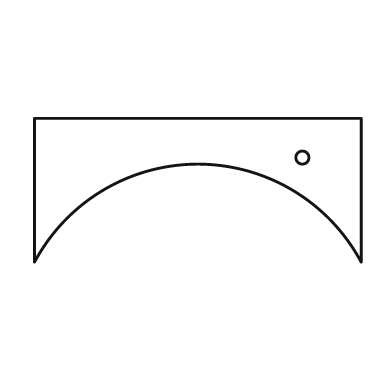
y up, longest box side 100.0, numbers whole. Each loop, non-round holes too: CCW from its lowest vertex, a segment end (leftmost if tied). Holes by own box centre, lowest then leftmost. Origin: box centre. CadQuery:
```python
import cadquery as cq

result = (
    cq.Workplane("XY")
    .moveTo(-50.0, -22.0)
    .threePointArc((0.0, 8.0), (50.0, -22.0))
    .lineTo(50.0, 22.0)
    .lineTo(-50.0, 22.0)
    .close()
    .moveTo(32.0, 10.0)
    .circle(2.0)
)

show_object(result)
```